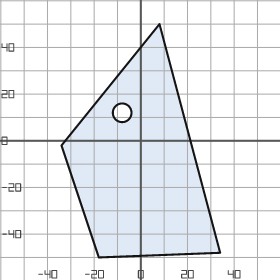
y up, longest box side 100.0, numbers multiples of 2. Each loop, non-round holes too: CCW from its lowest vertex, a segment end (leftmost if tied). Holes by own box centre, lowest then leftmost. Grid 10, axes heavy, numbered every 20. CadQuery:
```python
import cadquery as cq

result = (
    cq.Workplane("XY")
    .moveTo(-18.0, -50.0)
    .lineTo(34.0, -48.0)
    .lineTo(8.0, 50.0)
    .lineTo(-34.0, -2.0)
    .close()
    .moveTo(-8.0, 12.0)
    .circle(4.0)
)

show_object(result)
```